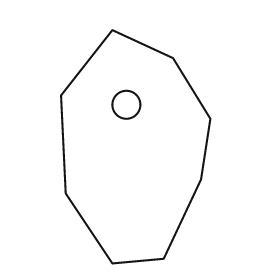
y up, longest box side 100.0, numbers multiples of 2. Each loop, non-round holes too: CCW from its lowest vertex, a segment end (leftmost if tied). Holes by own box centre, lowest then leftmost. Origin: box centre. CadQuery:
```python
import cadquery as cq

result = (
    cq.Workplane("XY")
    .moveTo(-10.0, -50.0)
    .lineTo(12.0, -48.0)
    .lineTo(28.0, -14.0)
    .lineTo(32.0, 12.0)
    .lineTo(16.0, 38.0)
    .lineTo(-10.0, 50.0)
    .lineTo(-32.0, 22.0)
    .lineTo(-30.0, -20.0)
    .close()
    .moveTo(-4.0, 18.0)
    .circle(6.0)
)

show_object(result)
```